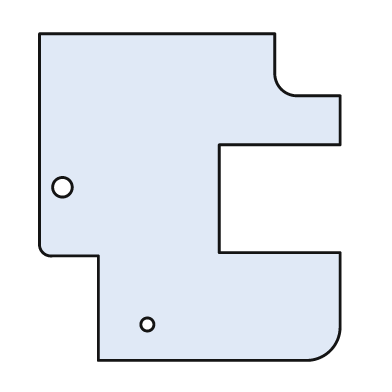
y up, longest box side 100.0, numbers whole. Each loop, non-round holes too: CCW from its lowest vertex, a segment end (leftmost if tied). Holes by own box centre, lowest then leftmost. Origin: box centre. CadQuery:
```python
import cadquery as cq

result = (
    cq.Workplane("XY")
    .moveTo(-28.0, -50.0)
    .lineTo(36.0, -50.0)
    .threePointArc((43.0, -47.0), (46.0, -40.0))
    .lineTo(46.0, -17.0)
    .lineTo(9.0, -17.0)
    .lineTo(9.0, 16.0)
    .lineTo(46.0, 16.0)
    .lineTo(46.0, 31.0)
    .lineTo(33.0, 31.0)
    .threePointArc((28.0, 33.0), (26.0, 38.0))
    .lineTo(26.0, 50.0)
    .lineTo(-46.0, 50.0)
    .lineTo(-46.0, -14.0)
    .threePointArc((-45.0, -17.0), (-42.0, -18.0))
    .lineTo(-28.0, -18.0)
    .close()
    .moveTo(-13.0, -39.0)
    .circle(2.0)
    .moveTo(-39.0, 3.0)
    .circle(3.0)
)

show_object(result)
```